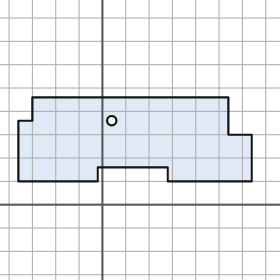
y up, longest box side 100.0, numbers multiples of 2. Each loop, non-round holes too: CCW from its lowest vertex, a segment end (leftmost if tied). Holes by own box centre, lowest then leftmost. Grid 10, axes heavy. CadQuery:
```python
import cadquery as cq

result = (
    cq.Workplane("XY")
    .moveTo(-36.0, 10.0)
    .lineTo(-2.0, 10.0)
    .lineTo(-2.0, 16.0)
    .lineTo(28.0, 16.0)
    .lineTo(28.0, 10.0)
    .lineTo(64.0, 10.0)
    .lineTo(64.0, 30.0)
    .lineTo(54.0, 30.0)
    .lineTo(54.0, 46.0)
    .lineTo(-30.0, 46.0)
    .lineTo(-30.0, 36.0)
    .lineTo(-36.0, 36.0)
    .close()
    .moveTo(4.0, 36.0)
    .circle(2.0)
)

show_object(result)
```